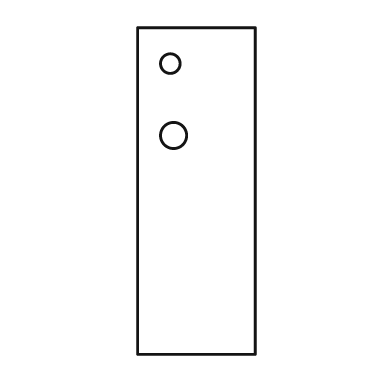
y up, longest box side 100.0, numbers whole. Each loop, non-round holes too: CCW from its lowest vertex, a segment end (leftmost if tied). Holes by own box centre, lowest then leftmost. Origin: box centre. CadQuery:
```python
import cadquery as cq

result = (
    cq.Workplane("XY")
    .moveTo(-18.0, -50.0)
    .lineTo(18.0, -50.0)
    .lineTo(18.0, 50.0)
    .lineTo(-18.0, 50.0)
    .close()
    .moveTo(-7.0, 17.0)
    .circle(4.0)
    .moveTo(-8.0, 39.0)
    .circle(3.0)
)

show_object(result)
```